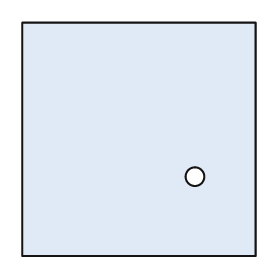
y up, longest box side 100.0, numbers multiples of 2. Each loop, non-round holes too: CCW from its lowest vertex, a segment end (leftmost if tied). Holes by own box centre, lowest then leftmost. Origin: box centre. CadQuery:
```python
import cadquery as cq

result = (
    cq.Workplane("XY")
    .moveTo(-50.0, -50.0)
    .lineTo(50.0, -50.0)
    .lineTo(50.0, 50.0)
    .lineTo(-50.0, 50.0)
    .close()
    .moveTo(24.0, -16.0)
    .circle(4.0)
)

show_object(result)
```